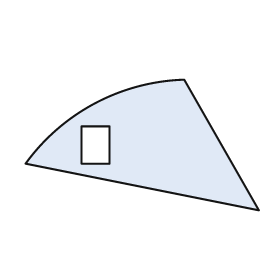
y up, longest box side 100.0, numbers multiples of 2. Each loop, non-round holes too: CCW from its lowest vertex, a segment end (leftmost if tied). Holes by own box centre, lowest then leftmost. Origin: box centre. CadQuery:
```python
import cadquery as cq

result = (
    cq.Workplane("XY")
    .moveTo(50.0, -28.0)
    .lineTo(18.0, 28.0)
    .threePointArc((-20.0, 18.0), (-50.0, -8.0))
    .close()
    .moveTo(-26.0, -8.0)
    .lineTo(-14.0, -8.0)
    .lineTo(-14.0, 8.0)
    .lineTo(-26.0, 8.0)
    .close()
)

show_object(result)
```